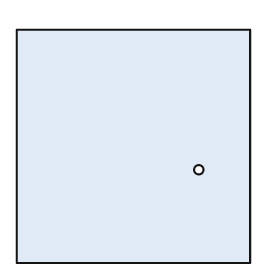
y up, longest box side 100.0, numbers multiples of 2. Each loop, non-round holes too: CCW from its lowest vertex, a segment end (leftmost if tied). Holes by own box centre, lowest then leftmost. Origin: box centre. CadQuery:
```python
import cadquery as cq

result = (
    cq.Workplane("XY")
    .moveTo(-50.0, -50.0)
    .lineTo(50.0, -50.0)
    .lineTo(50.0, 50.0)
    .lineTo(-50.0, 50.0)
    .close()
    .moveTo(28.0, -10.0)
    .circle(2.0)
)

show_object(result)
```